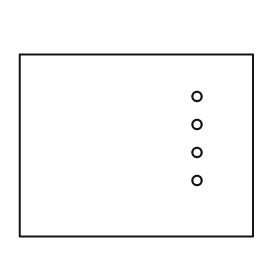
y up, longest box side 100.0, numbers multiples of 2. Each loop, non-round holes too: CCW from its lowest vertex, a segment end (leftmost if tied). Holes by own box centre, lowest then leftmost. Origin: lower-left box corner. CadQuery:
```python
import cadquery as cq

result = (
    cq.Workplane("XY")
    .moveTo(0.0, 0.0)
    .lineTo(100.0, 0.0)
    .lineTo(100.0, 78.0)
    .lineTo(0.0, 78.0)
    .close()
    .moveTo(76.0, 24.0)
    .circle(2.0)
    .moveTo(76.0, 36.0)
    .circle(2.0)
    .moveTo(76.0, 48.0)
    .circle(2.0)
    .moveTo(76.0, 60.0)
    .circle(2.0)
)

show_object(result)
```